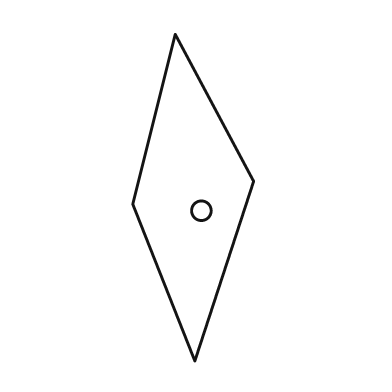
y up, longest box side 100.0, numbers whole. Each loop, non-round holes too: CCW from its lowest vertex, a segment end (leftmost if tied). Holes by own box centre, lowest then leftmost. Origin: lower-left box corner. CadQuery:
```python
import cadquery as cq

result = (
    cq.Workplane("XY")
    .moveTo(19.0, 0.0)
    .lineTo(37.0, 55.0)
    .lineTo(13.0, 100.0)
    .lineTo(0.0, 48.0)
    .close()
    .moveTo(21.0, 46.0)
    .circle(3.0)
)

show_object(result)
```